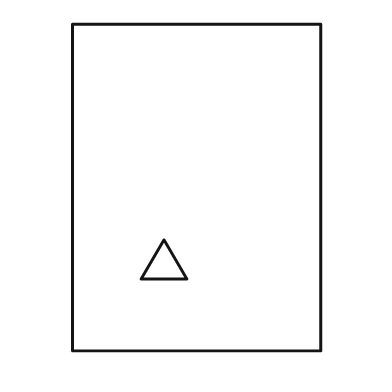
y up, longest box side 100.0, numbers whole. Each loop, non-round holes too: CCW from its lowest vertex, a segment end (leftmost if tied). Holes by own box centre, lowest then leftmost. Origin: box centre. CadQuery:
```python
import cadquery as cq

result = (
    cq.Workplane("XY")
    .moveTo(-38.0, -50.0)
    .lineTo(38.0, -50.0)
    .lineTo(38.0, 50.0)
    .lineTo(-38.0, 50.0)
    .close()
    .moveTo(-17.0, -28.0)
    .lineTo(-3.0, -28.0)
    .lineTo(-10.0, -16.0)
    .close()
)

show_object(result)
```